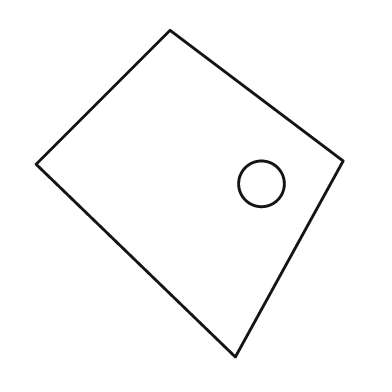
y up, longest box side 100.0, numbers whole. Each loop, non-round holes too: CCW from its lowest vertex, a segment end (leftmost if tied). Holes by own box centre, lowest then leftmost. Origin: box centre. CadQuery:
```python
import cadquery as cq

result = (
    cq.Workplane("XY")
    .moveTo(14.0, -50.0)
    .lineTo(47.0, 10.0)
    .lineTo(-6.0, 50.0)
    .lineTo(-47.0, 9.0)
    .close()
    .moveTo(22.0, 3.0)
    .circle(7.0)
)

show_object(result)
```